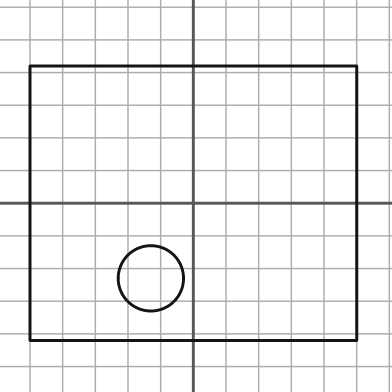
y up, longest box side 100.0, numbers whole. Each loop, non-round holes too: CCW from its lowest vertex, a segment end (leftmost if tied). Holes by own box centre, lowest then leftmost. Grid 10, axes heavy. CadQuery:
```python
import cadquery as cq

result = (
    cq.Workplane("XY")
    .moveTo(-50.0, -42.0)
    .lineTo(50.0, -42.0)
    .lineTo(50.0, 42.0)
    .lineTo(-50.0, 42.0)
    .close()
    .moveTo(-13.0, -23.0)
    .circle(10.0)
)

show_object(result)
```